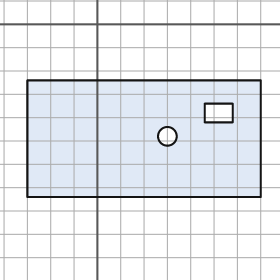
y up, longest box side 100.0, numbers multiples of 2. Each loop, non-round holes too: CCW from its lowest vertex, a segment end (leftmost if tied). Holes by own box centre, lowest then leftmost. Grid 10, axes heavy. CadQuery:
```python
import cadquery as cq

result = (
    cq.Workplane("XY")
    .moveTo(-30.0, -74.0)
    .lineTo(70.0, -74.0)
    .lineTo(70.0, -24.0)
    .lineTo(-30.0, -24.0)
    .close()
    .moveTo(30.0, -48.0)
    .circle(4.0)
    .moveTo(46.0, -42.0)
    .lineTo(58.0, -42.0)
    .lineTo(58.0, -34.0)
    .lineTo(46.0, -34.0)
    .close()
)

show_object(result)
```